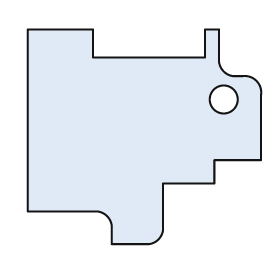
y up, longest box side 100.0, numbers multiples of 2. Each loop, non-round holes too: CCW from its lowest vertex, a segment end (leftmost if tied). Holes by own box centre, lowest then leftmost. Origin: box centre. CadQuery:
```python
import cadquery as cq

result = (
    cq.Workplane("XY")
    .moveTo(-14.0, -46.0)
    .lineTo(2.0, -46.0)
    .threePointArc((6.0, -44.0), (8.0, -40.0))
    .lineTo(8.0, -20.0)
    .lineTo(30.0, -20.0)
    .lineTo(30.0, -10.0)
    .lineTo(50.0, -10.0)
    .lineTo(50.0, 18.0)
    .threePointArc((48.0, 24.0), (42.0, 26.0))
    .lineTo(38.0, 26.0)
    .threePointArc((34.0, 28.0), (32.0, 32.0))
    .lineTo(32.0, 46.0)
    .lineTo(26.0, 46.0)
    .lineTo(26.0, 34.0)
    .lineTo(-22.0, 34.0)
    .lineTo(-22.0, 46.0)
    .lineTo(-50.0, 46.0)
    .lineTo(-50.0, -32.0)
    .lineTo(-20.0, -32.0)
    .threePointArc((-16.0, -34.0), (-14.0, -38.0))
    .close()
    .moveTo(34.0, 16.0)
    .circle(6.0)
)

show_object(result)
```